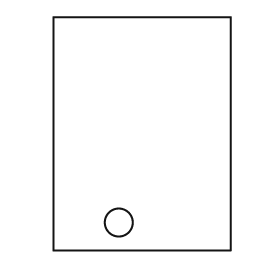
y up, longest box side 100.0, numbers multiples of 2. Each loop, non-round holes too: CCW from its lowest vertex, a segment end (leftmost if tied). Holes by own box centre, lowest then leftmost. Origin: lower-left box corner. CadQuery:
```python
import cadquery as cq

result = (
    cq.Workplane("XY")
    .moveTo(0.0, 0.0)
    .lineTo(76.0, 0.0)
    .lineTo(76.0, 100.0)
    .lineTo(0.0, 100.0)
    .close()
    .moveTo(28.0, 12.0)
    .circle(6.0)
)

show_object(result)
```